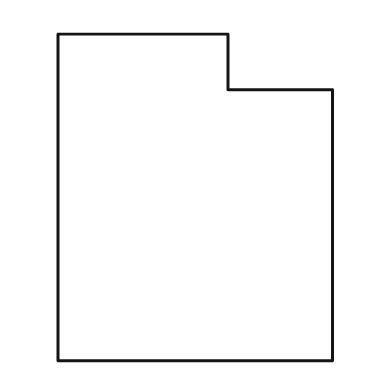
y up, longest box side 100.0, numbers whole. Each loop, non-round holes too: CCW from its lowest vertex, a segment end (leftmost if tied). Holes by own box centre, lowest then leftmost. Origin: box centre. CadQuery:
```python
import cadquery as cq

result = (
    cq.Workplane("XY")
    .moveTo(-42.0, -50.0)
    .lineTo(42.0, -50.0)
    .lineTo(42.0, 33.0)
    .lineTo(10.0, 33.0)
    .lineTo(10.0, 50.0)
    .lineTo(-42.0, 50.0)
    .close()
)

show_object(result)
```